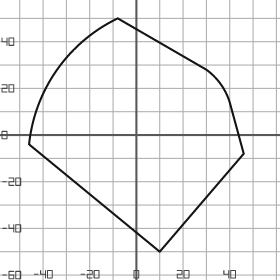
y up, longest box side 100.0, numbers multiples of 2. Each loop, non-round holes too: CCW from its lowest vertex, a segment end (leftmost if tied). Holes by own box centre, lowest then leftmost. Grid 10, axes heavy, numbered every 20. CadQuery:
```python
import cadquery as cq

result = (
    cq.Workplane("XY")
    .moveTo(10.0, -50.0)
    .lineTo(46.0, -8.0)
    .lineTo(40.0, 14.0)
    .threePointArc((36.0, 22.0), (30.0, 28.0))
    .lineTo(-8.0, 50.0)
    .threePointArc((-34.0, 28.0), (-46.0, -4.0))
    .close()
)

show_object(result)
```